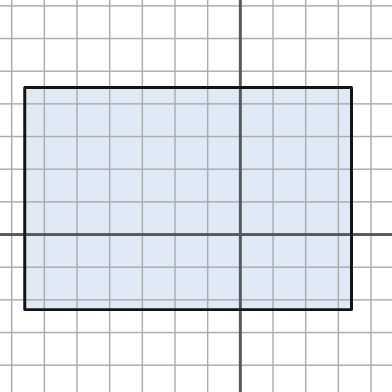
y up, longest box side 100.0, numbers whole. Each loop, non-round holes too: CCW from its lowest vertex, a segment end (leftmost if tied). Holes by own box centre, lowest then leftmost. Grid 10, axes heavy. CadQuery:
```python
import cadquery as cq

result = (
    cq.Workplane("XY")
    .moveTo(-66.0, -23.0)
    .lineTo(34.0, -23.0)
    .lineTo(34.0, 45.0)
    .lineTo(-66.0, 45.0)
    .close()
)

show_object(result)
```